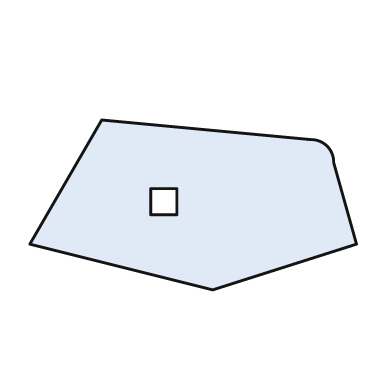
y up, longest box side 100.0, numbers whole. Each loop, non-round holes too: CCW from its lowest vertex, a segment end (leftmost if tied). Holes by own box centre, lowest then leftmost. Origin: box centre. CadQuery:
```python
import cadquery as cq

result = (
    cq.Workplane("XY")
    .moveTo(6.0, -26.0)
    .lineTo(50.0, -12.0)
    .lineTo(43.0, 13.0)
    .threePointArc((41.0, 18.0), (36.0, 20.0))
    .lineTo(-28.0, 26.0)
    .lineTo(-50.0, -12.0)
    .close()
    .moveTo(-13.0, -3.0)
    .lineTo(-5.0, -3.0)
    .lineTo(-5.0, 5.0)
    .lineTo(-13.0, 5.0)
    .close()
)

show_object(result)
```